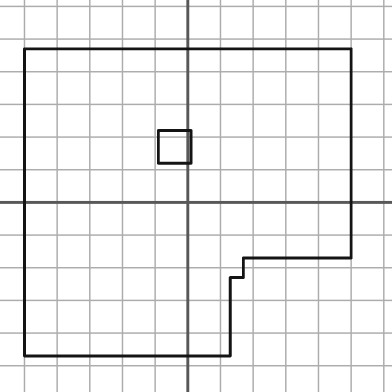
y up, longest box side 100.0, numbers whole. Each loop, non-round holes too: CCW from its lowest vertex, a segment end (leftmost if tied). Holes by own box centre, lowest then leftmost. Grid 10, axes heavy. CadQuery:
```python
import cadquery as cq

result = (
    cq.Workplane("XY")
    .moveTo(-50.0, -47.0)
    .lineTo(13.0, -47.0)
    .lineTo(13.0, -23.0)
    .lineTo(17.0, -23.0)
    .lineTo(17.0, -17.0)
    .lineTo(50.0, -17.0)
    .lineTo(50.0, 47.0)
    .lineTo(-50.0, 47.0)
    .close()
    .moveTo(-9.0, 12.0)
    .lineTo(1.0, 12.0)
    .lineTo(1.0, 22.0)
    .lineTo(-9.0, 22.0)
    .close()
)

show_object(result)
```